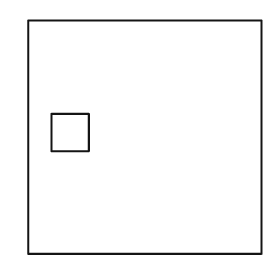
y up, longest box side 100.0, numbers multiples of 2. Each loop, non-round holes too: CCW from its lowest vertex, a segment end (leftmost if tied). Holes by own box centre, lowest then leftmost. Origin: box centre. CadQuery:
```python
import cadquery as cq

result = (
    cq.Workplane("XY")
    .moveTo(-50.0, -50.0)
    .lineTo(50.0, -50.0)
    .lineTo(50.0, 50.0)
    .lineTo(-50.0, 50.0)
    .close()
    .moveTo(-40.0, -6.0)
    .lineTo(-24.0, -6.0)
    .lineTo(-24.0, 10.0)
    .lineTo(-40.0, 10.0)
    .close()
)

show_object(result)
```